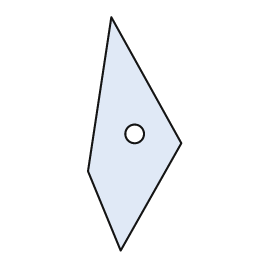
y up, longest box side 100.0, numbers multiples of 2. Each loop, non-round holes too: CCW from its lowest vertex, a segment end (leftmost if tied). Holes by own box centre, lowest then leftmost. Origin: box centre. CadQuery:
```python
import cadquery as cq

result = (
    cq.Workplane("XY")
    .moveTo(-6.0, -50.0)
    .lineTo(20.0, -4.0)
    .lineTo(-10.0, 50.0)
    .lineTo(-20.0, -16.0)
    .close()
    .moveTo(0.0, 0.0)
    .circle(4.0)
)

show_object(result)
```